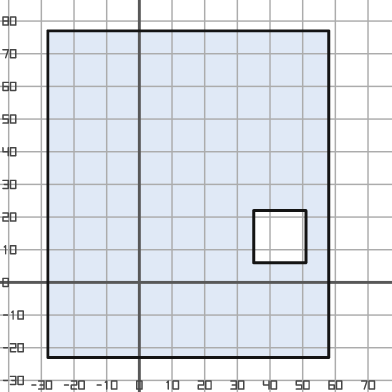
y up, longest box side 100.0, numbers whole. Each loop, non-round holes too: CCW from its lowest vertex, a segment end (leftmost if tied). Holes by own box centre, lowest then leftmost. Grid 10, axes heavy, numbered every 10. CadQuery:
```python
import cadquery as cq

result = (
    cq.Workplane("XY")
    .moveTo(-28.0, -23.0)
    .lineTo(58.0, -23.0)
    .lineTo(58.0, 77.0)
    .lineTo(-28.0, 77.0)
    .close()
    .moveTo(35.0, 6.0)
    .lineTo(51.0, 6.0)
    .lineTo(51.0, 22.0)
    .lineTo(35.0, 22.0)
    .close()
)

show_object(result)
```